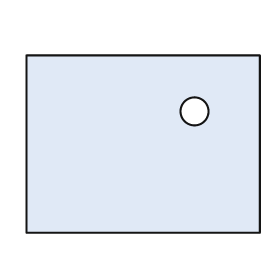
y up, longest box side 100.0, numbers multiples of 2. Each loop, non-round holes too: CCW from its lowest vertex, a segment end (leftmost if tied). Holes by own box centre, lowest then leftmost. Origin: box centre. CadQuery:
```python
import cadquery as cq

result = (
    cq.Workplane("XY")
    .moveTo(-50.0, -38.0)
    .lineTo(50.0, -38.0)
    .lineTo(50.0, 38.0)
    .lineTo(-50.0, 38.0)
    .close()
    .moveTo(22.0, 14.0)
    .circle(6.0)
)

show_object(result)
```